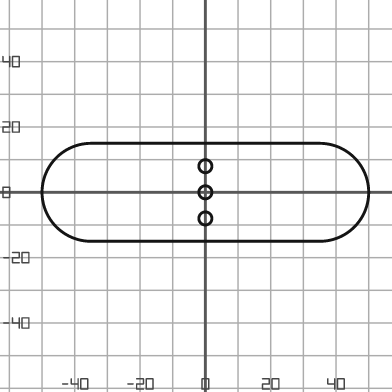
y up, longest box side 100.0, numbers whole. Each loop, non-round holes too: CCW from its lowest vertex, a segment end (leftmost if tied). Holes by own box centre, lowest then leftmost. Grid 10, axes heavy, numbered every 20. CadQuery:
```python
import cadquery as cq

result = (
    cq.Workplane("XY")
    .moveTo(-35.0, -15.0)
    .lineTo(35.0, -15.0)
    .threePointArc((50.0, 0.0), (35.0, 15.0))
    .lineTo(-35.0, 15.0)
    .threePointArc((-50.0, 0.0), (-35.0, -15.0))
    .close()
    .moveTo(0.0, -8.0)
    .circle(2.0)
    .moveTo(0.0, 0.0)
    .circle(2.0)
    .moveTo(0.0, 8.0)
    .circle(2.0)
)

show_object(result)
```